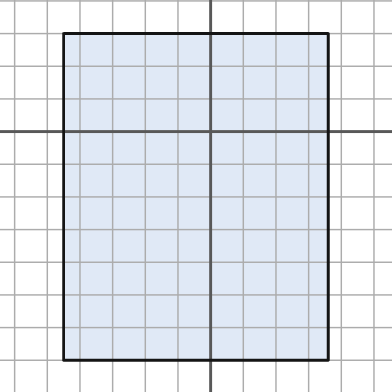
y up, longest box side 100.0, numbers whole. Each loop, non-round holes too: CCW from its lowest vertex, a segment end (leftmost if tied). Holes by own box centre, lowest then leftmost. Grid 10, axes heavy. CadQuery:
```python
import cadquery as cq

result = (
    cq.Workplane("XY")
    .moveTo(-45.0, -70.0)
    .lineTo(36.0, -70.0)
    .lineTo(36.0, 30.0)
    .lineTo(-45.0, 30.0)
    .close()
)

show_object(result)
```